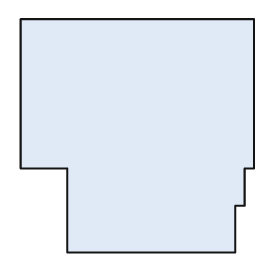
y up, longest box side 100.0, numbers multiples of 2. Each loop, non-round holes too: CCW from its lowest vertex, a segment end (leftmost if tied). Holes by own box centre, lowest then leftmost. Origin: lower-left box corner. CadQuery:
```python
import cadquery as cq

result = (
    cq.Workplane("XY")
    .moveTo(20.0, 0.0)
    .lineTo(92.0, 0.0)
    .lineTo(92.0, 20.0)
    .lineTo(96.0, 20.0)
    .lineTo(96.0, 36.0)
    .lineTo(100.0, 36.0)
    .lineTo(100.0, 100.0)
    .lineTo(0.0, 100.0)
    .lineTo(0.0, 36.0)
    .lineTo(20.0, 36.0)
    .close()
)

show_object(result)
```